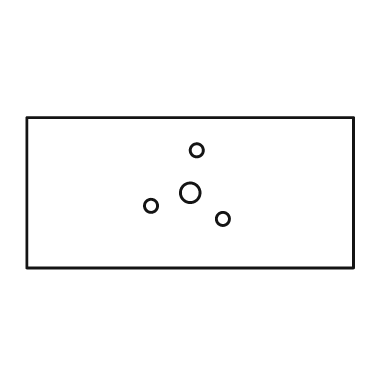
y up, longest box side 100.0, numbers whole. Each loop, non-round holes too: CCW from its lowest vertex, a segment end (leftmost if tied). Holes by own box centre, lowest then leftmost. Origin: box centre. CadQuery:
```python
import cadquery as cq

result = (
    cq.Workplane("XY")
    .moveTo(-50.0, -23.0)
    .lineTo(50.0, -23.0)
    .lineTo(50.0, 23.0)
    .lineTo(-50.0, 23.0)
    .close()
    .moveTo(10.0, -8.0)
    .circle(2.0)
    .moveTo(-12.0, -4.0)
    .circle(2.0)
    .moveTo(0.0, 0.0)
    .circle(3.0)
    .moveTo(2.0, 13.0)
    .circle(2.0)
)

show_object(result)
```